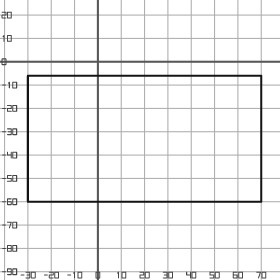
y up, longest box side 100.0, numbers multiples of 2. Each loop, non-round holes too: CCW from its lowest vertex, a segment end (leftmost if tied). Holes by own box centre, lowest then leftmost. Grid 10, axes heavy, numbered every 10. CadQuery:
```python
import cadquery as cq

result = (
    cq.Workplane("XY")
    .moveTo(-30.0, -60.0)
    .lineTo(70.0, -60.0)
    .lineTo(70.0, -6.0)
    .lineTo(-30.0, -6.0)
    .close()
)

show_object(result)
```